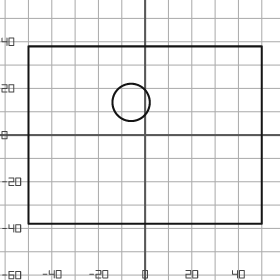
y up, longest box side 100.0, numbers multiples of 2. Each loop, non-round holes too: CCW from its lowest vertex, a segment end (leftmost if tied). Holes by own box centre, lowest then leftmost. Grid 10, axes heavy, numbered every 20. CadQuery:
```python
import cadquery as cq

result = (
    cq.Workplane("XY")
    .moveTo(-50.0, -38.0)
    .lineTo(50.0, -38.0)
    .lineTo(50.0, 38.0)
    .lineTo(-50.0, 38.0)
    .close()
    .moveTo(-6.0, 14.0)
    .circle(8.0)
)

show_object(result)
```